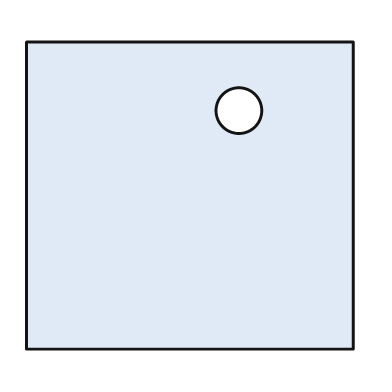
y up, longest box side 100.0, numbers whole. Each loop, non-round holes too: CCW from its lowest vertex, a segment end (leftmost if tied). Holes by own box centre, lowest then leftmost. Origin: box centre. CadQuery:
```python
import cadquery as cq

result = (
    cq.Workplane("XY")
    .moveTo(-50.0, -47.0)
    .lineTo(50.0, -47.0)
    .lineTo(50.0, 47.0)
    .lineTo(-50.0, 47.0)
    .close()
    .moveTo(15.0, 26.0)
    .circle(7.0)
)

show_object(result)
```